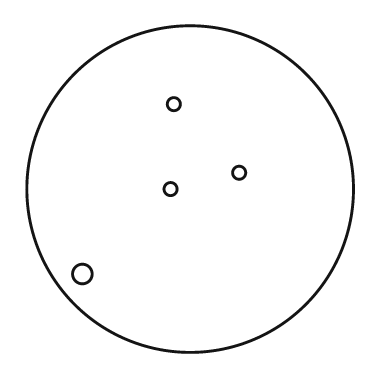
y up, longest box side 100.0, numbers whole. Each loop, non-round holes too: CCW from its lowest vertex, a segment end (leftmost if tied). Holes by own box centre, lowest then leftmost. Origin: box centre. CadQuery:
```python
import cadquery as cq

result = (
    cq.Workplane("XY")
    .moveTo(0.0, 0.0)
    .circle(50.0)
    .moveTo(-33.0, -26.0)
    .circle(3.0)
    .moveTo(-6.0, 0.0)
    .circle(2.0)
    .moveTo(15.0, 5.0)
    .circle(2.0)
    .moveTo(-5.0, 26.0)
    .circle(2.0)
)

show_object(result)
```